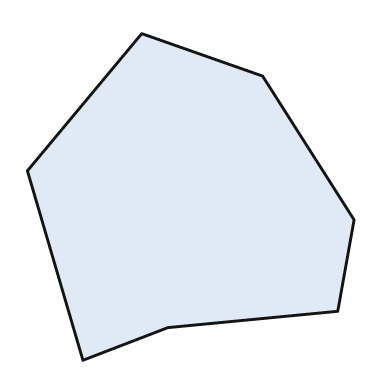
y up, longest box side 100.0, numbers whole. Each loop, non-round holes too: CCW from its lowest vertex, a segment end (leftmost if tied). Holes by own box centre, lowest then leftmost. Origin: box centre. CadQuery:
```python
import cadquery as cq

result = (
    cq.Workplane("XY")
    .moveTo(-33.0, -50.0)
    .lineTo(-7.0, -40.0)
    .lineTo(45.0, -35.0)
    .lineTo(50.0, -7.0)
    .lineTo(22.0, 37.0)
    .lineTo(-15.0, 50.0)
    .lineTo(-50.0, 8.0)
    .close()
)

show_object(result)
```